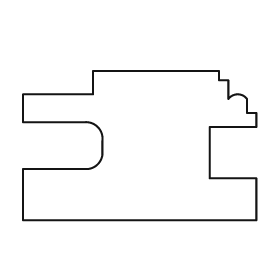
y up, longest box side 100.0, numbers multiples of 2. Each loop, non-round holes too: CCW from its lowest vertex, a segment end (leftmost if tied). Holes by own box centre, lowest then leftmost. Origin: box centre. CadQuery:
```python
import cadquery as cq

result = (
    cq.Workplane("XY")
    .moveTo(-50.0, -32.0)
    .lineTo(50.0, -32.0)
    .lineTo(50.0, -14.0)
    .lineTo(30.0, -14.0)
    .lineTo(30.0, 8.0)
    .lineTo(50.0, 8.0)
    .lineTo(50.0, 14.0)
    .lineTo(46.0, 14.0)
    .lineTo(46.0, 20.0)
    .threePointArc((42.0, 22.0), (38.0, 20.0))
    .lineTo(38.0, 28.0)
    .lineTo(34.0, 28.0)
    .lineTo(34.0, 32.0)
    .lineTo(-20.0, 32.0)
    .lineTo(-20.0, 22.0)
    .lineTo(-50.0, 22.0)
    .lineTo(-50.0, 10.0)
    .lineTo(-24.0, 10.0)
    .threePointArc((-18.0, 8.0), (-16.0, 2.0))
    .lineTo(-16.0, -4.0)
    .threePointArc((-18.0, -8.0), (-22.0, -10.0))
    .lineTo(-50.0, -10.0)
    .close()
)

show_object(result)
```